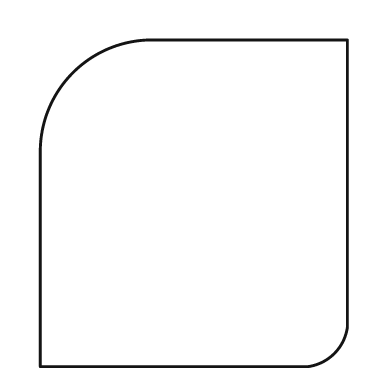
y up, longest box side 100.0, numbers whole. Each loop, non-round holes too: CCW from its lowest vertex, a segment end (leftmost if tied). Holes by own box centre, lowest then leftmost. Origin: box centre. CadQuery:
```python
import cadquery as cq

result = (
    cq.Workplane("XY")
    .moveTo(-47.0, -50.0)
    .lineTo(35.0, -50.0)
    .threePointArc((43.0, -46.0), (47.0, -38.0))
    .lineTo(47.0, 50.0)
    .lineTo(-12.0, 50.0)
    .threePointArc((-37.0, 40.0), (-47.0, 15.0))
    .close()
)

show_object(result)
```